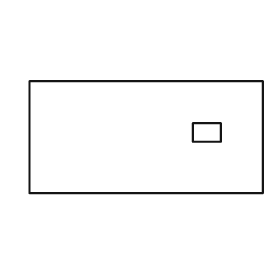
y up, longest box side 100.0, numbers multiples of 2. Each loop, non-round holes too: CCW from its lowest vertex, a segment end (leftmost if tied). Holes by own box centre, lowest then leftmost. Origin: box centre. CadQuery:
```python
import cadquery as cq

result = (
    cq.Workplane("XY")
    .moveTo(-50.0, -24.0)
    .lineTo(50.0, -24.0)
    .lineTo(50.0, 24.0)
    .lineTo(-50.0, 24.0)
    .close()
    .moveTo(20.0, -2.0)
    .lineTo(32.0, -2.0)
    .lineTo(32.0, 6.0)
    .lineTo(20.0, 6.0)
    .close()
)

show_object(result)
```